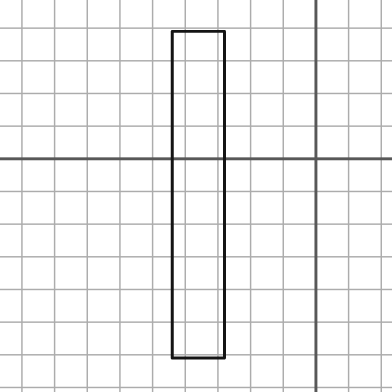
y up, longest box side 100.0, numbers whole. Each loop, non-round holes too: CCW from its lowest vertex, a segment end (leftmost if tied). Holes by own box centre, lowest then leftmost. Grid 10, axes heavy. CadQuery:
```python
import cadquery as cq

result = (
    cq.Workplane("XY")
    .moveTo(-44.0, -61.0)
    .lineTo(-28.0, -61.0)
    .lineTo(-28.0, 39.0)
    .lineTo(-44.0, 39.0)
    .close()
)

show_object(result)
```